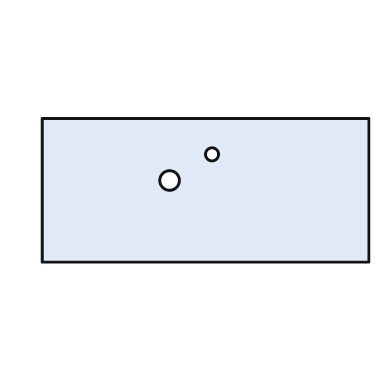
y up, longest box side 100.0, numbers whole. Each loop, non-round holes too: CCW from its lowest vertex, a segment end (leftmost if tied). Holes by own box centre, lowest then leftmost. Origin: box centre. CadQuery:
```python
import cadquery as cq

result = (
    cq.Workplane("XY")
    .moveTo(-50.0, -22.0)
    .lineTo(50.0, -22.0)
    .lineTo(50.0, 22.0)
    .lineTo(-50.0, 22.0)
    .close()
    .moveTo(-11.0, 3.0)
    .circle(3.0)
    .moveTo(2.0, 11.0)
    .circle(2.0)
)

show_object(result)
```